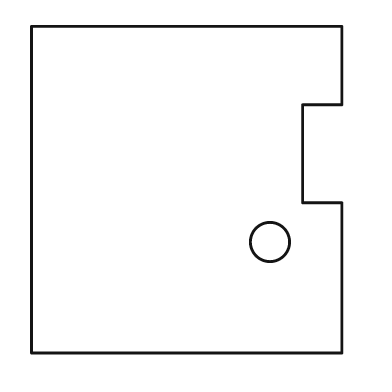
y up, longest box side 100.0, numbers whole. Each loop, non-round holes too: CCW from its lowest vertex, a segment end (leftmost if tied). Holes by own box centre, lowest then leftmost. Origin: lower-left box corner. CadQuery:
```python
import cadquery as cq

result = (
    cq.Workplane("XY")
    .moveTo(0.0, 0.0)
    .lineTo(95.0, 0.0)
    .lineTo(95.0, 46.0)
    .lineTo(83.0, 46.0)
    .lineTo(83.0, 76.0)
    .lineTo(95.0, 76.0)
    .lineTo(95.0, 100.0)
    .lineTo(0.0, 100.0)
    .close()
    .moveTo(73.0, 34.0)
    .circle(6.0)
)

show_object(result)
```